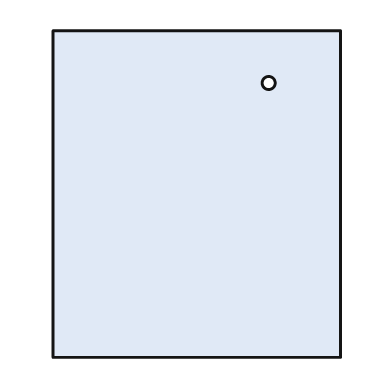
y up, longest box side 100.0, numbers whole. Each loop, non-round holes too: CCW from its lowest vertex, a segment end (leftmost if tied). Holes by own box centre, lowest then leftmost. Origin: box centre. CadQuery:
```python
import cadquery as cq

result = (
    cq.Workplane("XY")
    .moveTo(-44.0, -50.0)
    .lineTo(44.0, -50.0)
    .lineTo(44.0, 50.0)
    .lineTo(-44.0, 50.0)
    .close()
    .moveTo(22.0, 34.0)
    .circle(2.0)
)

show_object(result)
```